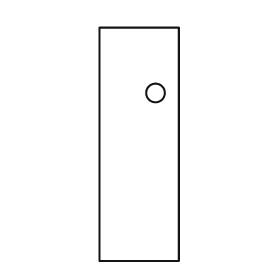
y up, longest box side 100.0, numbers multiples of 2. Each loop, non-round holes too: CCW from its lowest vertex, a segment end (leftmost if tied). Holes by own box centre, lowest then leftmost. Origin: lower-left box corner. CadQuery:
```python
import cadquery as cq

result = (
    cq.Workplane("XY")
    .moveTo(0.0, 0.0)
    .lineTo(34.0, 0.0)
    .lineTo(34.0, 100.0)
    .lineTo(0.0, 100.0)
    .close()
    .moveTo(24.0, 72.0)
    .circle(4.0)
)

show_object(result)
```